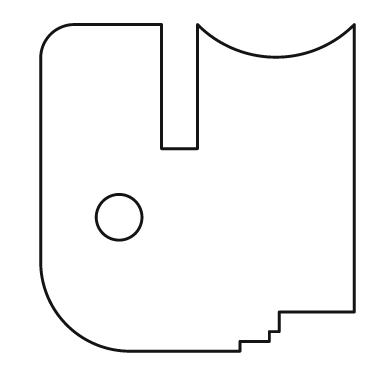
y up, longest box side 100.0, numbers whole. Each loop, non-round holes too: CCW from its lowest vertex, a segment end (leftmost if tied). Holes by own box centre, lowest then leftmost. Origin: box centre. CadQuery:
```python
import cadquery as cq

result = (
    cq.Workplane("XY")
    .moveTo(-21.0, -50.0)
    .lineTo(13.0, -50.0)
    .lineTo(13.0, -47.0)
    .lineTo(22.0, -47.0)
    .lineTo(22.0, -44.0)
    .lineTo(25.0, -44.0)
    .lineTo(25.0, -38.0)
    .lineTo(48.0, -38.0)
    .lineTo(48.0, 50.0)
    .threePointArc((24.0, 40.0), (0.0, 50.0))
    .lineTo(0.0, 12.0)
    .lineTo(-11.0, 12.0)
    .lineTo(-11.0, 50.0)
    .lineTo(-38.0, 50.0)
    .threePointArc((-45.0, 47.0), (-48.0, 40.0))
    .lineTo(-48.0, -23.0)
    .threePointArc((-40.0, -42.0), (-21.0, -50.0))
    .close()
    .moveTo(-24.0, -9.0)
    .circle(7.0)
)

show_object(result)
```